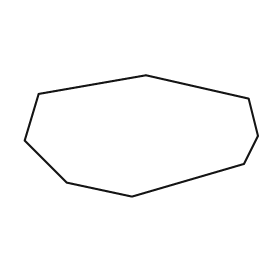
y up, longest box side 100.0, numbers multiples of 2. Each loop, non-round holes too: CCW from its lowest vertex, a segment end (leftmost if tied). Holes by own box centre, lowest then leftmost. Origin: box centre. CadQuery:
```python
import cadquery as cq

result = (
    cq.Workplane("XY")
    .moveTo(-4.0, -26.0)
    .lineTo(44.0, -12.0)
    .lineTo(50.0, 0.0)
    .lineTo(46.0, 16.0)
    .lineTo(2.0, 26.0)
    .lineTo(-44.0, 18.0)
    .lineTo(-50.0, -2.0)
    .lineTo(-32.0, -20.0)
    .close()
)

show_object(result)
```